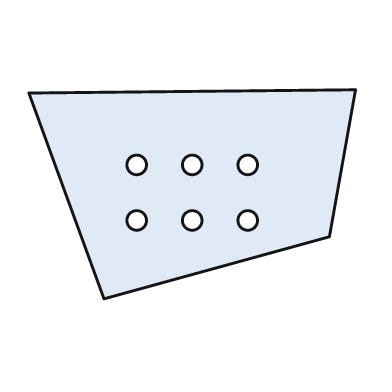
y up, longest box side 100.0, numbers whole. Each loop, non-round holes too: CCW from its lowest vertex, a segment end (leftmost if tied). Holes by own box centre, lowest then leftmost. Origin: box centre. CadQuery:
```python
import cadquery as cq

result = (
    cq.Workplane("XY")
    .moveTo(-27.0, -32.0)
    .lineTo(42.0, -13.0)
    .lineTo(50.0, 32.0)
    .lineTo(-50.0, 31.0)
    .close()
    .moveTo(-17.0, -8.0)
    .circle(3.0)
    .moveTo(0.0, -8.0)
    .circle(3.0)
    .moveTo(17.0, -8.0)
    .circle(3.0)
    .moveTo(-17.0, 9.0)
    .circle(3.0)
    .moveTo(0.0, 9.0)
    .circle(3.0)
    .moveTo(17.0, 9.0)
    .circle(3.0)
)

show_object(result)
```